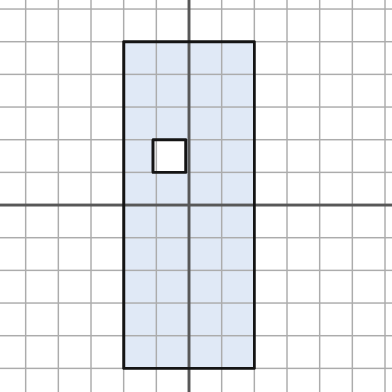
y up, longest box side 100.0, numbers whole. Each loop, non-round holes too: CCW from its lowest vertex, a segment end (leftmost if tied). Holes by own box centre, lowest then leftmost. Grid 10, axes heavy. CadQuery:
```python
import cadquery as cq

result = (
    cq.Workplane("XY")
    .moveTo(-20.0, -50.0)
    .lineTo(20.0, -50.0)
    .lineTo(20.0, 50.0)
    .lineTo(-20.0, 50.0)
    .close()
    .moveTo(-11.0, 10.0)
    .lineTo(-1.0, 10.0)
    .lineTo(-1.0, 20.0)
    .lineTo(-11.0, 20.0)
    .close()
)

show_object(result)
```